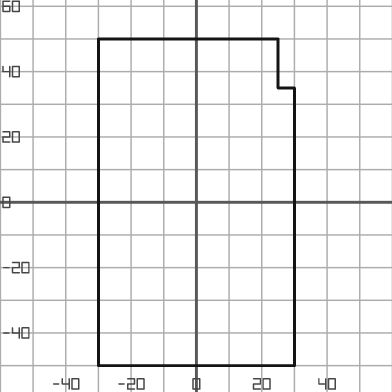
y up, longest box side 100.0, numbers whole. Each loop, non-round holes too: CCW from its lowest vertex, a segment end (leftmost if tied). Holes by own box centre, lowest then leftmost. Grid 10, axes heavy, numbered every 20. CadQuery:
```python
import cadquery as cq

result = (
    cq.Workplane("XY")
    .moveTo(-30.0, -50.0)
    .lineTo(30.0, -50.0)
    .lineTo(30.0, 35.0)
    .lineTo(25.0, 35.0)
    .lineTo(25.0, 50.0)
    .lineTo(-30.0, 50.0)
    .close()
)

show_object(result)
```